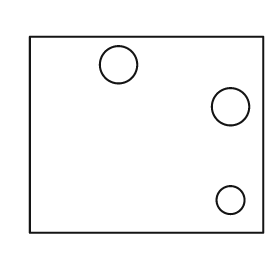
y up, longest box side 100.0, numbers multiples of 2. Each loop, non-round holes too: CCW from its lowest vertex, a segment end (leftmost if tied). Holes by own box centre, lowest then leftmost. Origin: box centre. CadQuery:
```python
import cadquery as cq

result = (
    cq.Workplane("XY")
    .moveTo(-50.0, -42.0)
    .lineTo(50.0, -42.0)
    .lineTo(50.0, 42.0)
    .lineTo(-50.0, 42.0)
    .close()
    .moveTo(36.0, -28.0)
    .circle(6.0)
    .moveTo(36.0, 12.0)
    .circle(8.0)
    .moveTo(-12.0, 30.0)
    .circle(8.0)
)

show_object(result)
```